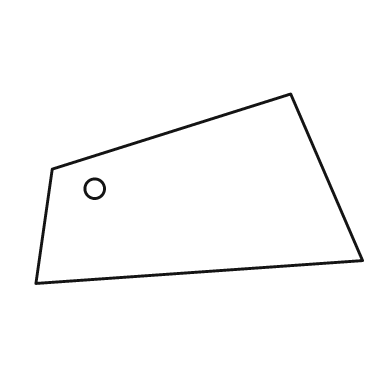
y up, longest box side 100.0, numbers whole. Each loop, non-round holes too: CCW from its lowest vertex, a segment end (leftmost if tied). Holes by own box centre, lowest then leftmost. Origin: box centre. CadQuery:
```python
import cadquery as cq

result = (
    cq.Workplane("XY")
    .moveTo(-50.0, -29.0)
    .lineTo(50.0, -22.0)
    .lineTo(28.0, 29.0)
    .lineTo(-45.0, 6.0)
    .close()
    .moveTo(-32.0, 0.0)
    .circle(3.0)
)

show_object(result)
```